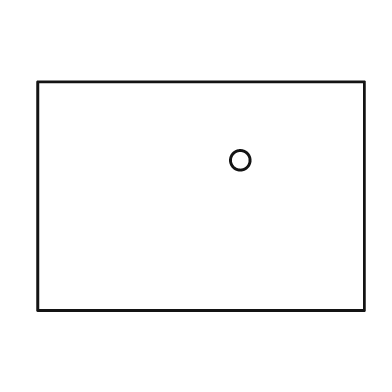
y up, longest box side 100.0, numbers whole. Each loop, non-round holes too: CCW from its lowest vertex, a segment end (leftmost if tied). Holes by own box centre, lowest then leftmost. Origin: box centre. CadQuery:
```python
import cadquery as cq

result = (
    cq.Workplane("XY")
    .moveTo(-50.0, -35.0)
    .lineTo(50.0, -35.0)
    .lineTo(50.0, 35.0)
    .lineTo(-50.0, 35.0)
    .close()
    .moveTo(12.0, 11.0)
    .circle(3.0)
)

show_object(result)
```